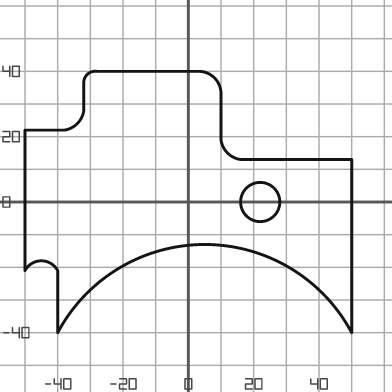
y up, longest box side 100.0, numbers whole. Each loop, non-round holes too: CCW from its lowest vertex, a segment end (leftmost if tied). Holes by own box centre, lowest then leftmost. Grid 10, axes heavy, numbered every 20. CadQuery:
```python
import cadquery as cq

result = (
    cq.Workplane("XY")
    .moveTo(-40.0, -40.0)
    .threePointArc((5.0, -13.0), (50.0, -40.0))
    .lineTo(50.0, 13.0)
    .lineTo(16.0, 13.0)
    .threePointArc((12.0, 15.0), (10.0, 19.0))
    .lineTo(10.0, 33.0)
    .threePointArc((8.0, 38.0), (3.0, 40.0))
    .lineTo(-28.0, 40.0)
    .threePointArc((-31.0, 39.0), (-32.0, 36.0))
    .lineTo(-32.0, 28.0)
    .threePointArc((-34.0, 24.0), (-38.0, 22.0))
    .lineTo(-50.0, 22.0)
    .lineTo(-50.0, -21.0)
    .threePointArc((-45.0, -18.0), (-40.0, -21.0))
    .close()
    .moveTo(22.0, 0.0)
    .circle(6.0)
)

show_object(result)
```